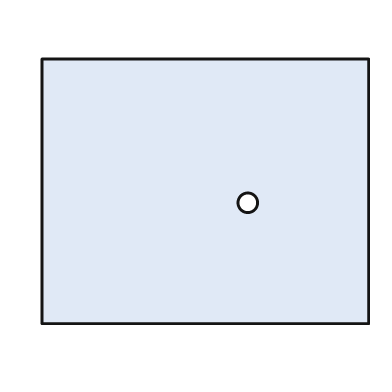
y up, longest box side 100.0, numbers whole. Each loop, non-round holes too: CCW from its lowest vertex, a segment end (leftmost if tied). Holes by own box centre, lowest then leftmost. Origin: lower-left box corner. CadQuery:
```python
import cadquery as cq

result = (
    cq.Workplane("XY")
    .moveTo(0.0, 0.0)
    .lineTo(100.0, 0.0)
    .lineTo(100.0, 81.0)
    .lineTo(0.0, 81.0)
    .close()
    .moveTo(63.0, 37.0)
    .circle(3.0)
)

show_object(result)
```